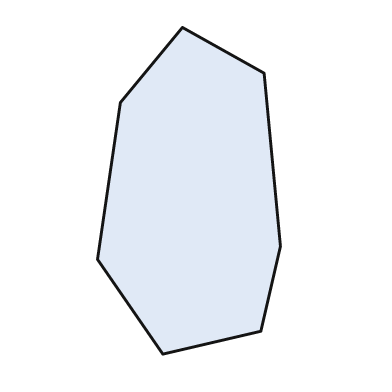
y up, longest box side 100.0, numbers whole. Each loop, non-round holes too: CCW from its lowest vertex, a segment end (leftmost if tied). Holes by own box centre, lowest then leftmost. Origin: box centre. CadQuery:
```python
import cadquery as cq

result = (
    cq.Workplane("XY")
    .moveTo(-8.0, -50.0)
    .lineTo(22.0, -43.0)
    .lineTo(28.0, -17.0)
    .lineTo(23.0, 36.0)
    .lineTo(-2.0, 50.0)
    .lineTo(-21.0, 27.0)
    .lineTo(-28.0, -21.0)
    .close()
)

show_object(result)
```